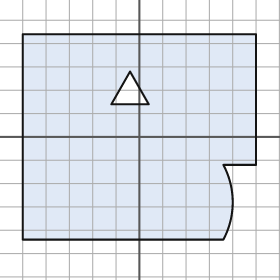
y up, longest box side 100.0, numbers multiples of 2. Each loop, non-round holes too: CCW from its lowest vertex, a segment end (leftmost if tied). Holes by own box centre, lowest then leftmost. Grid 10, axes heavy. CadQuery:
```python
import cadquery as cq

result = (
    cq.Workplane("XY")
    .moveTo(-50.0, -44.0)
    .lineTo(36.0, -44.0)
    .threePointArc((40.0, -28.0), (36.0, -12.0))
    .lineTo(50.0, -12.0)
    .lineTo(50.0, 44.0)
    .lineTo(-50.0, 44.0)
    .close()
    .moveTo(-12.0, 14.0)
    .lineTo(4.0, 14.0)
    .lineTo(-4.0, 28.0)
    .close()
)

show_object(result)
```